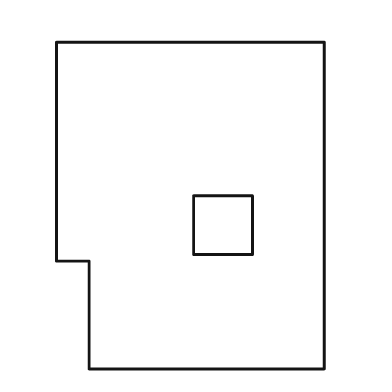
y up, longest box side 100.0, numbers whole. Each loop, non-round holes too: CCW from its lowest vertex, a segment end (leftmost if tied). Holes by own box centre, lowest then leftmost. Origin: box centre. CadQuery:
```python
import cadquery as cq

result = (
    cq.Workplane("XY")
    .moveTo(-31.0, -50.0)
    .lineTo(41.0, -50.0)
    .lineTo(41.0, 50.0)
    .lineTo(-41.0, 50.0)
    .lineTo(-41.0, -17.0)
    .lineTo(-31.0, -17.0)
    .close()
    .moveTo(1.0, -15.0)
    .lineTo(19.0, -15.0)
    .lineTo(19.0, 3.0)
    .lineTo(1.0, 3.0)
    .close()
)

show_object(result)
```